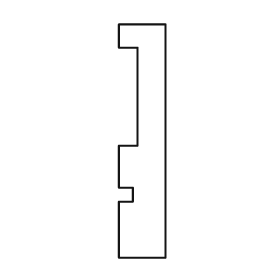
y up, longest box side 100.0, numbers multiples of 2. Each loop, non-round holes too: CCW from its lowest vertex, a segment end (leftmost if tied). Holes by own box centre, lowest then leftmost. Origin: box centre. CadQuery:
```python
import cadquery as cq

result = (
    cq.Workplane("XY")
    .moveTo(-10.0, -50.0)
    .lineTo(10.0, -50.0)
    .lineTo(10.0, 50.0)
    .lineTo(-10.0, 50.0)
    .lineTo(-10.0, 40.0)
    .lineTo(-2.0, 40.0)
    .lineTo(-2.0, -2.0)
    .lineTo(-10.0, -2.0)
    .lineTo(-10.0, -20.0)
    .lineTo(-4.0, -20.0)
    .lineTo(-4.0, -26.0)
    .lineTo(-10.0, -26.0)
    .close()
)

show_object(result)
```